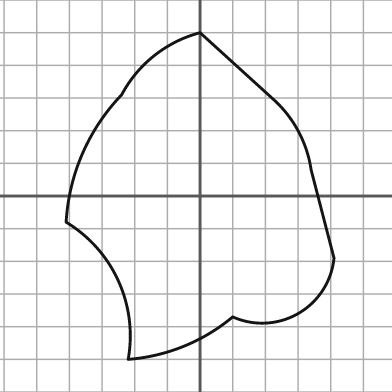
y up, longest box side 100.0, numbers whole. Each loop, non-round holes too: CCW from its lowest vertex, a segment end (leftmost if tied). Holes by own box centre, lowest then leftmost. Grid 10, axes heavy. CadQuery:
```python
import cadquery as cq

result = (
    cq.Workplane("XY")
    .moveTo(-22.0, -50.0)
    .threePointArc((-5.0, -46.0), (10.0, -37.0))
    .threePointArc((30.0, -36.0), (41.0, -19.0))
    .lineTo(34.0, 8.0)
    .threePointArc((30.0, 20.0), (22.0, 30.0))
    .lineTo(0.0, 50.0)
    .threePointArc((-14.0, 43.0), (-24.0, 31.0))
    .threePointArc((-36.0, 13.0), (-41.0, -8.0))
    .threePointArc((-25.0, -26.0), (-22.0, -50.0))
    .close()
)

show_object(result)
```